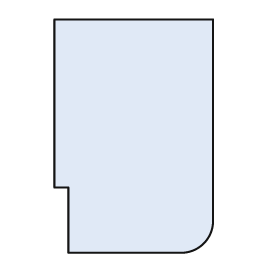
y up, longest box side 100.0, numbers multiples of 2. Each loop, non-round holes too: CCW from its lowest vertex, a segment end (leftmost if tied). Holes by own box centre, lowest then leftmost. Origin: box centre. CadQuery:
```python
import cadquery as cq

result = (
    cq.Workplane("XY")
    .moveTo(-28.0, -50.0)
    .lineTo(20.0, -50.0)
    .threePointArc((30.0, -46.0), (34.0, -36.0))
    .lineTo(34.0, 50.0)
    .lineTo(-34.0, 50.0)
    .lineTo(-34.0, -22.0)
    .lineTo(-28.0, -22.0)
    .close()
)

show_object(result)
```